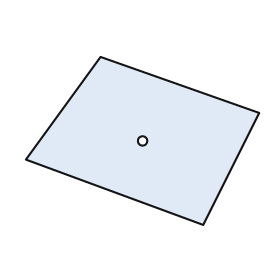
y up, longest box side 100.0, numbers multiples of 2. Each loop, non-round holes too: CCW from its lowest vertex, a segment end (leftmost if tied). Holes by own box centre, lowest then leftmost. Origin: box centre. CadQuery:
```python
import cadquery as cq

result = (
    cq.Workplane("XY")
    .moveTo(26.0, -36.0)
    .lineTo(50.0, 12.0)
    .lineTo(-18.0, 36.0)
    .lineTo(-50.0, -8.0)
    .close()
    .moveTo(0.0, 0.0)
    .circle(2.0)
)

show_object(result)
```